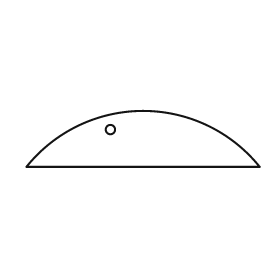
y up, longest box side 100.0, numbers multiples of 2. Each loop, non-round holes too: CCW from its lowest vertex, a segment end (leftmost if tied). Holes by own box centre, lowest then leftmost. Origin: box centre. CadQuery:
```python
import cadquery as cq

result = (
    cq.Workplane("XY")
    .moveTo(-50.0, -12.0)
    .lineTo(50.0, -12.0)
    .threePointArc((0.0, 12.0), (-50.0, -12.0))
    .close()
    .moveTo(-14.0, 4.0)
    .circle(2.0)
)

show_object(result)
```